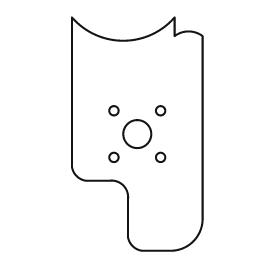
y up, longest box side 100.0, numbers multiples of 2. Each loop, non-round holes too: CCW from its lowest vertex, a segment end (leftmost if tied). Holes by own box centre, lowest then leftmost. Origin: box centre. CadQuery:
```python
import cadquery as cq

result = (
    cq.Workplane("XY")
    .moveTo(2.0, -50.0)
    .lineTo(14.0, -50.0)
    .threePointArc((24.0, -46.0), (28.0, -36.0))
    .lineTo(28.0, 42.0)
    .threePointArc((22.0, 44.0), (16.0, 42.0))
    .lineTo(16.0, 50.0)
    .threePointArc((-6.0, 40.0), (-28.0, 50.0))
    .lineTo(-28.0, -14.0)
    .threePointArc((-26.0, -18.0), (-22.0, -20.0))
    .lineTo(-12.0, -20.0)
    .threePointArc((-6.0, -22.0), (-4.0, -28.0))
    .lineTo(-4.0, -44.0)
    .threePointArc((-2.0, -48.0), (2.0, -50.0))
    .close()
    .moveTo(-10.0, -10.0)
    .circle(2.0)
    .moveTo(10.0, -10.0)
    .circle(2.0)
    .moveTo(0.0, 0.0)
    .circle(6.0)
    .moveTo(-10.0, 10.0)
    .circle(2.0)
    .moveTo(10.0, 10.0)
    .circle(2.0)
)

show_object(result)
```